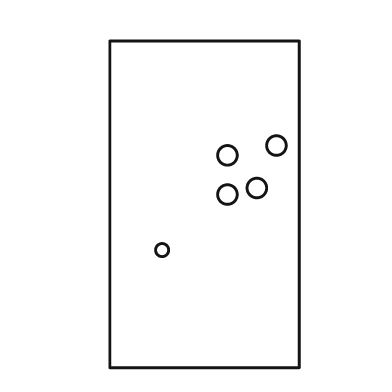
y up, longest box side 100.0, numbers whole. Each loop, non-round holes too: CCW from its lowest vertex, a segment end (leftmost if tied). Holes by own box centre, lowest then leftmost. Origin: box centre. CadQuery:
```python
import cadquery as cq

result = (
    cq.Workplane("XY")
    .moveTo(-29.0, -50.0)
    .lineTo(29.0, -50.0)
    .lineTo(29.0, 50.0)
    .lineTo(-29.0, 50.0)
    .close()
    .moveTo(-13.0, -14.0)
    .circle(2.0)
    .moveTo(7.0, 3.0)
    .circle(3.0)
    .moveTo(16.0, 5.0)
    .circle(3.0)
    .moveTo(7.0, 15.0)
    .circle(3.0)
    .moveTo(22.0, 18.0)
    .circle(3.0)
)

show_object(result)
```